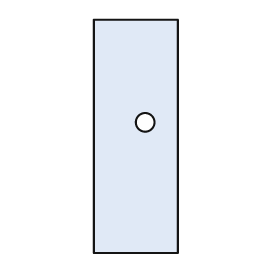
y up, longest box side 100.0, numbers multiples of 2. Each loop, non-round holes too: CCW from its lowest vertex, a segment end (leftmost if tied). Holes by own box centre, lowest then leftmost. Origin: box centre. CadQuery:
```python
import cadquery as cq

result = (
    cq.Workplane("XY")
    .moveTo(-18.0, -50.0)
    .lineTo(18.0, -50.0)
    .lineTo(18.0, 50.0)
    .lineTo(-18.0, 50.0)
    .close()
    .moveTo(4.0, 6.0)
    .circle(4.0)
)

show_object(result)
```